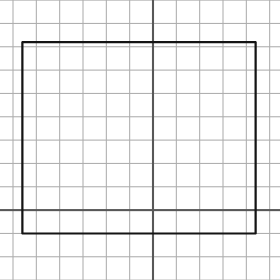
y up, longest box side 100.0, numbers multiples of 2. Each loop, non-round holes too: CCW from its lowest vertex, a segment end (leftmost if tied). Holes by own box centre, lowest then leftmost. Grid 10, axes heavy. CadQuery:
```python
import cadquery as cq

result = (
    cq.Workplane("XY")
    .moveTo(-56.0, -10.0)
    .lineTo(44.0, -10.0)
    .lineTo(44.0, 72.0)
    .lineTo(-56.0, 72.0)
    .close()
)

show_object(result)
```